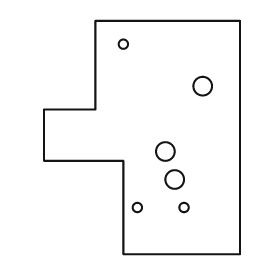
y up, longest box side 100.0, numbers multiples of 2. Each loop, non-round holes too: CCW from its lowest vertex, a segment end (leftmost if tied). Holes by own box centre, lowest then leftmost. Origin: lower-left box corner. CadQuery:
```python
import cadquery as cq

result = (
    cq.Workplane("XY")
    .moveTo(34.0, 0.0)
    .lineTo(84.0, 0.0)
    .lineTo(84.0, 100.0)
    .lineTo(22.0, 100.0)
    .lineTo(22.0, 62.0)
    .lineTo(0.0, 62.0)
    .lineTo(0.0, 40.0)
    .lineTo(34.0, 40.0)
    .close()
    .moveTo(40.0, 20.0)
    .circle(2.0)
    .moveTo(60.0, 20.0)
    .circle(2.0)
    .moveTo(56.0, 32.0)
    .circle(4.0)
    .moveTo(52.0, 44.0)
    .circle(4.0)
    .moveTo(68.0, 72.0)
    .circle(4.0)
    .moveTo(34.0, 90.0)
    .circle(2.0)
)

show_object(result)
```